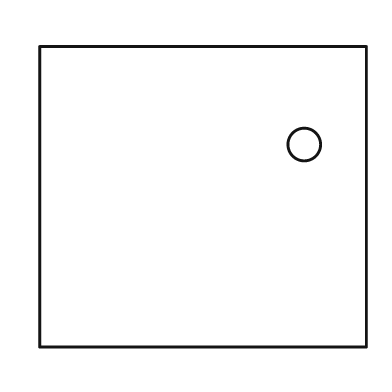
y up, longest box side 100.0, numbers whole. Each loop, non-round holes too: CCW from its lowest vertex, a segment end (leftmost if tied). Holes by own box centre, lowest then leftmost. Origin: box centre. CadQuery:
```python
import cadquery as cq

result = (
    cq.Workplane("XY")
    .moveTo(-50.0, -46.0)
    .lineTo(50.0, -46.0)
    .lineTo(50.0, 46.0)
    .lineTo(-50.0, 46.0)
    .close()
    .moveTo(31.0, 16.0)
    .circle(5.0)
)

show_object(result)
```